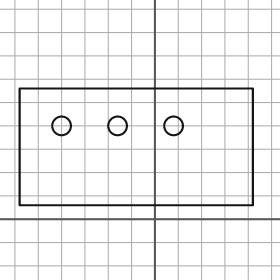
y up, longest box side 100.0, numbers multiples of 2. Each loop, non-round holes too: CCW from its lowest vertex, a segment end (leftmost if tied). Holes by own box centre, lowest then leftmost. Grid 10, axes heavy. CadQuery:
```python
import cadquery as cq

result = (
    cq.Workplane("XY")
    .moveTo(-58.0, 6.0)
    .lineTo(42.0, 6.0)
    .lineTo(42.0, 56.0)
    .lineTo(-58.0, 56.0)
    .close()
    .moveTo(-40.0, 40.0)
    .circle(4.0)
    .moveTo(-16.0, 40.0)
    .circle(4.0)
    .moveTo(8.0, 40.0)
    .circle(4.0)
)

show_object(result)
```